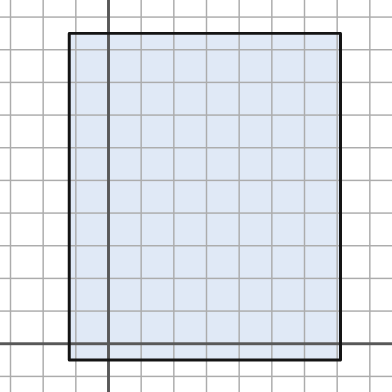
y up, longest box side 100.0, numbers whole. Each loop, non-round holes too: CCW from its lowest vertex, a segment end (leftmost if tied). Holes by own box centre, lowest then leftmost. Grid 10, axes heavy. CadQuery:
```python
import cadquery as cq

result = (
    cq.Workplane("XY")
    .moveTo(-12.0, -5.0)
    .lineTo(71.0, -5.0)
    .lineTo(71.0, 95.0)
    .lineTo(-12.0, 95.0)
    .close()
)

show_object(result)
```